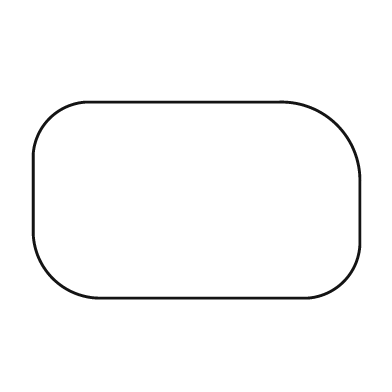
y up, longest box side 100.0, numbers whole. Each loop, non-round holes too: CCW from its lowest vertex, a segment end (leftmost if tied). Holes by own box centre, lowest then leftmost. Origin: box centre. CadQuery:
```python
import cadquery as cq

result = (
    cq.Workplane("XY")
    .moveTo(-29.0, -30.0)
    .lineTo(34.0, -30.0)
    .threePointArc((45.0, -25.0), (50.0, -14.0))
    .lineTo(50.0, 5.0)
    .threePointArc((43.0, 23.0), (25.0, 30.0))
    .lineTo(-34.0, 30.0)
    .threePointArc((-45.0, 25.0), (-50.0, 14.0))
    .lineTo(-50.0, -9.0)
    .threePointArc((-44.0, -24.0), (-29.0, -30.0))
    .close()
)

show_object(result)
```